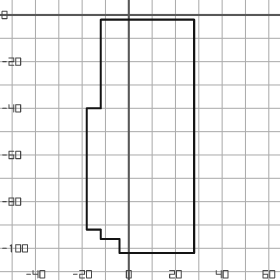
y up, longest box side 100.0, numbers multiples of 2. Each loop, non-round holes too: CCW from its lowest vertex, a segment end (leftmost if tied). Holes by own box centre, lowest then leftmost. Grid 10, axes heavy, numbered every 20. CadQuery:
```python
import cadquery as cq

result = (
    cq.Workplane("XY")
    .moveTo(-4.0, -102.0)
    .lineTo(28.0, -102.0)
    .lineTo(28.0, -2.0)
    .lineTo(-12.0, -2.0)
    .lineTo(-12.0, -40.0)
    .lineTo(-18.0, -40.0)
    .lineTo(-18.0, -92.0)
    .lineTo(-12.0, -92.0)
    .lineTo(-12.0, -96.0)
    .lineTo(-4.0, -96.0)
    .close()
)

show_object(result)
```